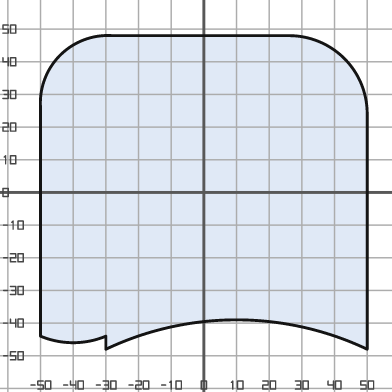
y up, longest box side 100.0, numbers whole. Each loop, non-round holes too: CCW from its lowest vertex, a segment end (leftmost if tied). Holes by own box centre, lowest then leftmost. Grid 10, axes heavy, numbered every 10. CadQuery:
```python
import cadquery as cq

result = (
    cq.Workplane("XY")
    .moveTo(-30.0, -48.0)
    .threePointArc((10.0, -39.0), (50.0, -48.0))
    .lineTo(50.0, 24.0)
    .threePointArc((43.0, 41.0), (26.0, 48.0))
    .lineTo(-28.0, 48.0)
    .threePointArc((-44.0, 42.0), (-50.0, 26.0))
    .lineTo(-50.0, -44.0)
    .threePointArc((-40.0, -46.0), (-30.0, -44.0))
    .close()
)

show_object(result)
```